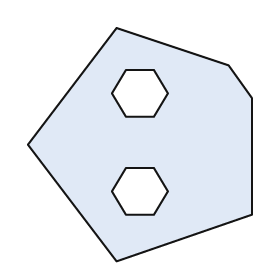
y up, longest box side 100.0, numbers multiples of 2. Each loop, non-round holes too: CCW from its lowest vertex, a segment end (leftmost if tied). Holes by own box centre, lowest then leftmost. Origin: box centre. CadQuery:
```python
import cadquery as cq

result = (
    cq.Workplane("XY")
    .moveTo(-10.0, -50.0)
    .lineTo(48.0, -30.0)
    .lineTo(48.0, 20.0)
    .lineTo(38.0, 34.0)
    .lineTo(-10.0, 50.0)
    .lineTo(-48.0, 0.0)
    .close()
    .moveTo(-6.0, -30.0)
    .lineTo(6.0, -30.0)
    .lineTo(12.0, -20.0)
    .lineTo(6.0, -10.0)
    .lineTo(-6.0, -10.0)
    .lineTo(-12.0, -20.0)
    .close()
    .moveTo(-6.0, 12.0)
    .lineTo(6.0, 12.0)
    .lineTo(12.0, 22.0)
    .lineTo(6.0, 32.0)
    .lineTo(-6.0, 32.0)
    .lineTo(-12.0, 22.0)
    .close()
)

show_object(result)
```